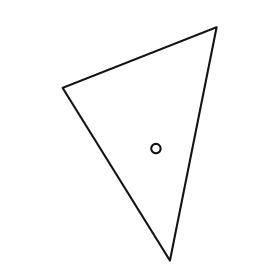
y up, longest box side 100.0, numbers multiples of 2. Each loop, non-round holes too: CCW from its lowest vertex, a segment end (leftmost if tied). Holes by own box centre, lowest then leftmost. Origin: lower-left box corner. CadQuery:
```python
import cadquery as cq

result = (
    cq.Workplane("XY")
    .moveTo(46.0, 0.0)
    .lineTo(66.0, 100.0)
    .lineTo(0.0, 74.0)
    .close()
    .moveTo(40.0, 48.0)
    .circle(2.0)
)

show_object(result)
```